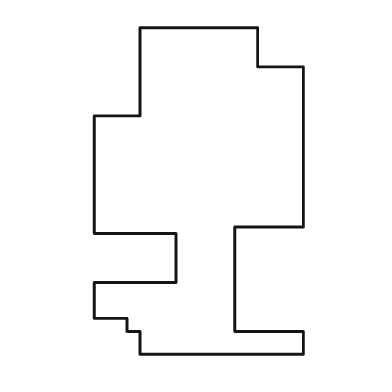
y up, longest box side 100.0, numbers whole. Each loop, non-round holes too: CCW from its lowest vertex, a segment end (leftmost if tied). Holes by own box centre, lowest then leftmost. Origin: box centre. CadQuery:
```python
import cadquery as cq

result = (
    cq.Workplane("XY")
    .moveTo(-18.0, -50.0)
    .lineTo(32.0, -50.0)
    .lineTo(32.0, -43.0)
    .lineTo(11.0, -43.0)
    .lineTo(11.0, -11.0)
    .lineTo(32.0, -11.0)
    .lineTo(32.0, 38.0)
    .lineTo(18.0, 38.0)
    .lineTo(18.0, 50.0)
    .lineTo(-18.0, 50.0)
    .lineTo(-18.0, 23.0)
    .lineTo(-32.0, 23.0)
    .lineTo(-32.0, -13.0)
    .lineTo(-7.0, -13.0)
    .lineTo(-7.0, -28.0)
    .lineTo(-32.0, -28.0)
    .lineTo(-32.0, -39.0)
    .lineTo(-22.0, -39.0)
    .lineTo(-22.0, -43.0)
    .lineTo(-18.0, -43.0)
    .close()
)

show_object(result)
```